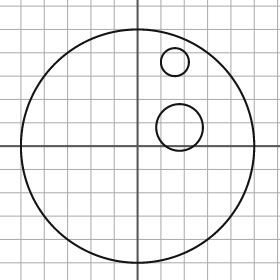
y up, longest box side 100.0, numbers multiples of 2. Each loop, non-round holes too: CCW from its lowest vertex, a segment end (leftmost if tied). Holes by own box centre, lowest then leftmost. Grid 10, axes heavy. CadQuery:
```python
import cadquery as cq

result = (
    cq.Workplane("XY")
    .moveTo(0.0, 0.0)
    .circle(50.0)
    .moveTo(18.0, 8.0)
    .circle(10.0)
    .moveTo(16.0, 36.0)
    .circle(6.0)
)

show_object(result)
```